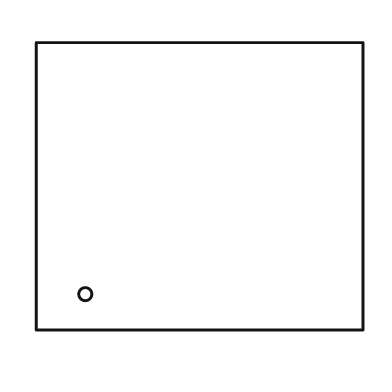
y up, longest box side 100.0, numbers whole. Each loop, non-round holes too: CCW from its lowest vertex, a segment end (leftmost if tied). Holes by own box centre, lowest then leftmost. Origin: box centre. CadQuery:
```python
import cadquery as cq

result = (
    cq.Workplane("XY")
    .moveTo(-50.0, -44.0)
    .lineTo(50.0, -44.0)
    .lineTo(50.0, 44.0)
    .lineTo(-50.0, 44.0)
    .close()
    .moveTo(-35.0, -33.0)
    .circle(2.0)
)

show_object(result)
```